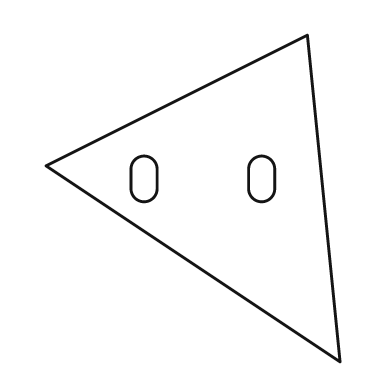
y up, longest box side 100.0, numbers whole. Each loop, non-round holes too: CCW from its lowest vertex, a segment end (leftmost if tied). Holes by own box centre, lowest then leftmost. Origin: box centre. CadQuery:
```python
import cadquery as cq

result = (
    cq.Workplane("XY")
    .moveTo(45.0, -50.0)
    .lineTo(35.0, 50.0)
    .lineTo(-45.0, 10.0)
    .close()
    .moveTo(-19.0, 3.0)
    .threePointArc((-15.0, -1.0), (-11.0, 3.0))
    .lineTo(-11.0, 9.0)
    .threePointArc((-15.0, 13.0), (-19.0, 9.0))
    .close()
    .moveTo(17.0, 3.0)
    .threePointArc((21.0, -1.0), (25.0, 3.0))
    .lineTo(25.0, 9.0)
    .threePointArc((21.0, 13.0), (17.0, 9.0))
    .close()
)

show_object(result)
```